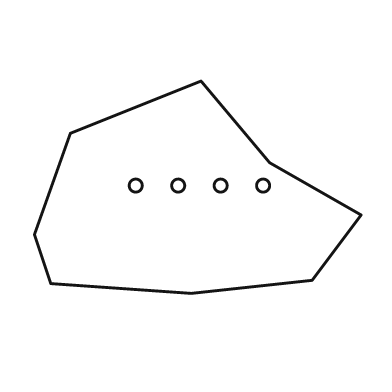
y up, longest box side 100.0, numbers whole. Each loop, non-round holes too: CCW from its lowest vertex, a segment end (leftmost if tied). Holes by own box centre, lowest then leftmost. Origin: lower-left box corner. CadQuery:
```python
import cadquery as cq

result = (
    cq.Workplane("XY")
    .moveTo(48.0, 0.0)
    .lineTo(85.0, 4.0)
    .lineTo(100.0, 24.0)
    .lineTo(72.0, 40.0)
    .lineTo(51.0, 65.0)
    .lineTo(11.0, 49.0)
    .lineTo(0.0, 18.0)
    .lineTo(5.0, 3.0)
    .close()
    .moveTo(31.0, 33.0)
    .circle(2.0)
    .moveTo(44.0, 33.0)
    .circle(2.0)
    .moveTo(57.0, 33.0)
    .circle(2.0)
    .moveTo(70.0, 33.0)
    .circle(2.0)
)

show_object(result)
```